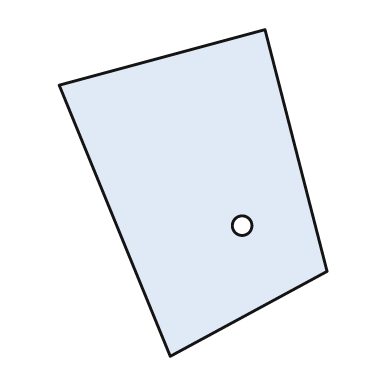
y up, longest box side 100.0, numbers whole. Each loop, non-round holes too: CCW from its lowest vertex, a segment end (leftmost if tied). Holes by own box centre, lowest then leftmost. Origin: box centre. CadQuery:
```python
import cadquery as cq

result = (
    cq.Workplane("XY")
    .moveTo(-7.0, -50.0)
    .lineTo(41.0, -24.0)
    .lineTo(22.0, 50.0)
    .lineTo(-41.0, 33.0)
    .close()
    .moveTo(15.0, -10.0)
    .circle(3.0)
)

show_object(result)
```